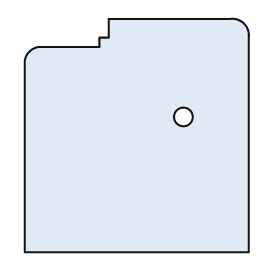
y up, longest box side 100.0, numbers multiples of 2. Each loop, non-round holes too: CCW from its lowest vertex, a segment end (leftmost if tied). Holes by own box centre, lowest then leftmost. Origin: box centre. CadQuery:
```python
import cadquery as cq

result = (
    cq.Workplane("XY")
    .moveTo(-48.0, -50.0)
    .lineTo(48.0, -50.0)
    .lineTo(48.0, 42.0)
    .threePointArc((46.0, 48.0), (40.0, 50.0))
    .lineTo(-12.0, 50.0)
    .lineTo(-12.0, 42.0)
    .lineTo(-16.0, 42.0)
    .lineTo(-16.0, 38.0)
    .lineTo(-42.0, 38.0)
    .threePointArc((-46.0, 36.0), (-48.0, 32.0))
    .close()
    .moveTo(20.0, 8.0)
    .circle(4.0)
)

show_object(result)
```